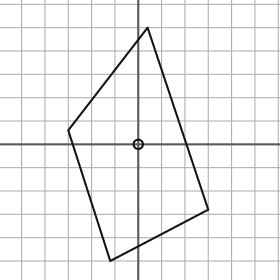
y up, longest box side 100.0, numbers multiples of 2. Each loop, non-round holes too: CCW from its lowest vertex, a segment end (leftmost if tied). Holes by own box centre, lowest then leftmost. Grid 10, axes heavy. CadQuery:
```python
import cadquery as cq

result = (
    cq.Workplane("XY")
    .moveTo(-12.0, -50.0)
    .lineTo(30.0, -28.0)
    .lineTo(4.0, 50.0)
    .lineTo(-30.0, 6.0)
    .close()
    .moveTo(0.0, 0.0)
    .circle(2.0)
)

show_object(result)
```